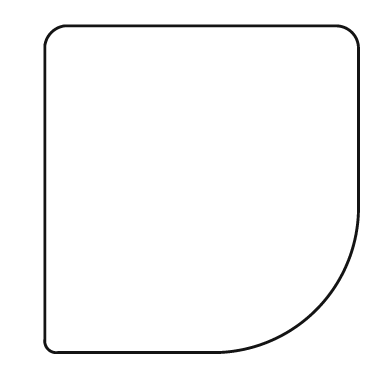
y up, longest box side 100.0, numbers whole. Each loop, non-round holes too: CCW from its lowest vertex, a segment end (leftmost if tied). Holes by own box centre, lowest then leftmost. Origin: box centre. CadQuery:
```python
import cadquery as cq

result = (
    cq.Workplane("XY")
    .moveTo(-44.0, -50.0)
    .lineTo(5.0, -50.0)
    .threePointArc((35.0, -37.0), (48.0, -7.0))
    .lineTo(48.0, 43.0)
    .threePointArc((46.0, 48.0), (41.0, 50.0))
    .lineTo(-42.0, 50.0)
    .threePointArc((-46.0, 48.0), (-48.0, 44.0))
    .lineTo(-48.0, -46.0)
    .threePointArc((-47.0, -49.0), (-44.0, -50.0))
    .close()
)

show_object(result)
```